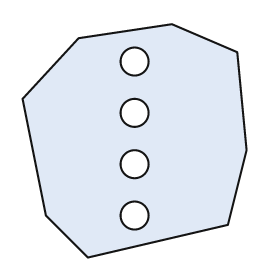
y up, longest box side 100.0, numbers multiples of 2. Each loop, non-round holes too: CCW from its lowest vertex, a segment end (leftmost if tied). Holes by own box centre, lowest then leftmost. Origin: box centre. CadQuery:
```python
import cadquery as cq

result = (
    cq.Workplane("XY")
    .moveTo(-20.0, -50.0)
    .lineTo(40.0, -36.0)
    .lineTo(48.0, -4.0)
    .lineTo(44.0, 38.0)
    .lineTo(16.0, 50.0)
    .lineTo(-24.0, 44.0)
    .lineTo(-48.0, 18.0)
    .lineTo(-38.0, -32.0)
    .close()
    .moveTo(0.0, -32.0)
    .circle(6.0)
    .moveTo(0.0, -10.0)
    .circle(6.0)
    .moveTo(0.0, 12.0)
    .circle(6.0)
    .moveTo(0.0, 34.0)
    .circle(6.0)
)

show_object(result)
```